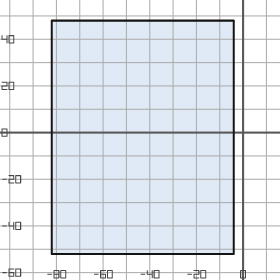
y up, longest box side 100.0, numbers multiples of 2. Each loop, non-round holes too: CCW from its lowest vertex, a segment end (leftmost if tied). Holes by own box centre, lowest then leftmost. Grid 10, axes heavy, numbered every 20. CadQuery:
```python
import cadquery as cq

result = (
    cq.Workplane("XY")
    .moveTo(-82.0, -52.0)
    .lineTo(-4.0, -52.0)
    .lineTo(-4.0, 48.0)
    .lineTo(-82.0, 48.0)
    .close()
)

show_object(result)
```